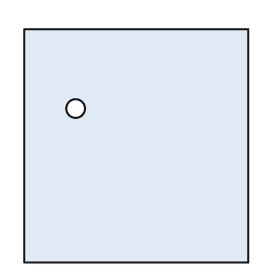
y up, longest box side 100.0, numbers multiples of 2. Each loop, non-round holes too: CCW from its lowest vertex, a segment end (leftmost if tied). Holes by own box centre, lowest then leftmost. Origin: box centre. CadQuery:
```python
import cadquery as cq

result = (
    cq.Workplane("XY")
    .moveTo(-48.0, -50.0)
    .lineTo(48.0, -50.0)
    .lineTo(48.0, 50.0)
    .lineTo(-48.0, 50.0)
    .close()
    .moveTo(-26.0, 16.0)
    .circle(4.0)
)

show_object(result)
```